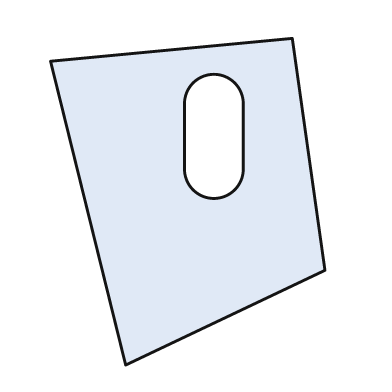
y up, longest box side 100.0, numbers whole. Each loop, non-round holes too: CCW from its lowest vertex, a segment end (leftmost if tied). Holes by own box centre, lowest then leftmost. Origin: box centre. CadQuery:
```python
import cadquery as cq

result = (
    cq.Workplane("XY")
    .moveTo(-19.0, -50.0)
    .lineTo(42.0, -21.0)
    .lineTo(32.0, 50.0)
    .lineTo(-42.0, 43.0)
    .close()
    .moveTo(-1.0, 10.0)
    .threePointArc((8.0, 1.0), (17.0, 10.0))
    .lineTo(17.0, 30.0)
    .threePointArc((8.0, 39.0), (-1.0, 30.0))
    .close()
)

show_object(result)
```